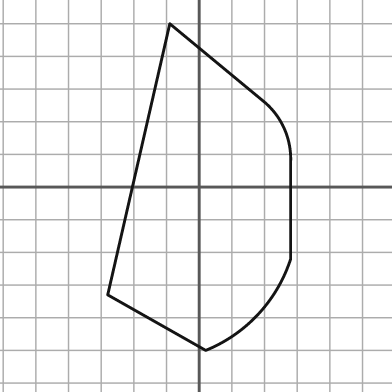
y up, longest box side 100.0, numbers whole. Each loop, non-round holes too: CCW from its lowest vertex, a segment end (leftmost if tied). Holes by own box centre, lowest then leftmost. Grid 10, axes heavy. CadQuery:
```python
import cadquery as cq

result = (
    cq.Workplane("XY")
    .moveTo(2.0, -50.0)
    .threePointArc((18.0, -39.0), (28.0, -22.0))
    .lineTo(28.0, 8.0)
    .threePointArc((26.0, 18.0), (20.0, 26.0))
    .lineTo(-9.0, 50.0)
    .lineTo(-28.0, -33.0)
    .close()
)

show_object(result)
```